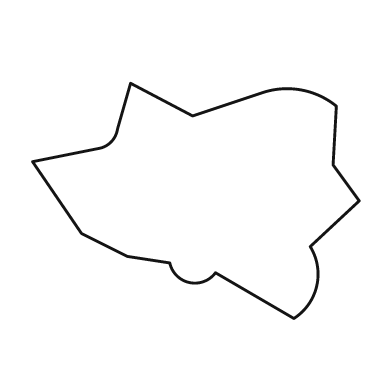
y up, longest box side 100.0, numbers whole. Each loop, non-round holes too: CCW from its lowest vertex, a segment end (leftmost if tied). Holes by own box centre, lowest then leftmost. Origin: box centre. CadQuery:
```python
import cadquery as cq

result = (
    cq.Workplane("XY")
    .moveTo(30.0, -36.0)
    .threePointArc((37.0, -26.0), (35.0, -14.0))
    .lineTo(50.0, 0.0)
    .lineTo(42.0, 11.0)
    .lineTo(43.0, 29.0)
    .threePointArc((32.0, 34.0), (20.0, 33.0))
    .lineTo(-1.0, 26.0)
    .lineTo(-20.0, 36.0)
    .lineTo(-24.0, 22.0)
    .threePointArc((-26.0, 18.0), (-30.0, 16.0))
    .lineTo(-50.0, 12.0)
    .lineTo(-35.0, -10.0)
    .lineTo(-21.0, -17.0)
    .lineTo(-8.0, -19.0)
    .threePointArc((-2.0, -25.0), (6.0, -22.0))
    .close()
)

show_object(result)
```